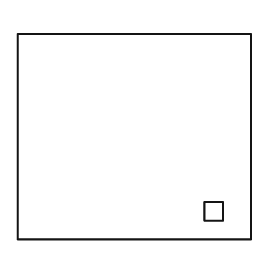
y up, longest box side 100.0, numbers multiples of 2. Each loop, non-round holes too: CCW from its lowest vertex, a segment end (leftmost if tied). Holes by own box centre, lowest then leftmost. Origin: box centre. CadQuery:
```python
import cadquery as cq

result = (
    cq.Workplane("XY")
    .moveTo(-50.0, -44.0)
    .lineTo(50.0, -44.0)
    .lineTo(50.0, 44.0)
    .lineTo(-50.0, 44.0)
    .close()
    .moveTo(30.0, -36.0)
    .lineTo(38.0, -36.0)
    .lineTo(38.0, -28.0)
    .lineTo(30.0, -28.0)
    .close()
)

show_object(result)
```